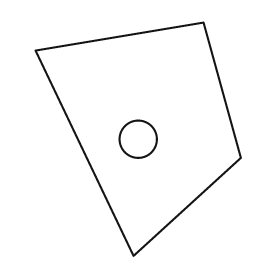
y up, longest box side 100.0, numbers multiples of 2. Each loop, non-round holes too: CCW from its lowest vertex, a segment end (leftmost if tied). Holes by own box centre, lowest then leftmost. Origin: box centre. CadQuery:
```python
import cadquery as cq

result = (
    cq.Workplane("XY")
    .moveTo(-2.0, -50.0)
    .lineTo(44.0, -8.0)
    .lineTo(28.0, 50.0)
    .lineTo(-44.0, 38.0)
    .close()
    .moveTo(0.0, 0.0)
    .circle(8.0)
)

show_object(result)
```